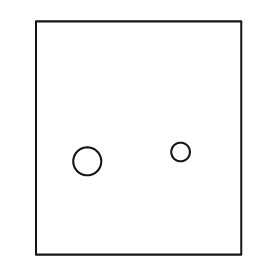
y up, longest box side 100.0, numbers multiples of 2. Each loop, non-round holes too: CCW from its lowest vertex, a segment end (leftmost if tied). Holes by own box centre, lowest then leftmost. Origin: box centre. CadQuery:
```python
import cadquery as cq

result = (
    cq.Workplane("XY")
    .moveTo(-44.0, -50.0)
    .lineTo(44.0, -50.0)
    .lineTo(44.0, 50.0)
    .lineTo(-44.0, 50.0)
    .close()
    .moveTo(-22.0, -10.0)
    .circle(6.0)
    .moveTo(18.0, -6.0)
    .circle(4.0)
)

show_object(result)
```